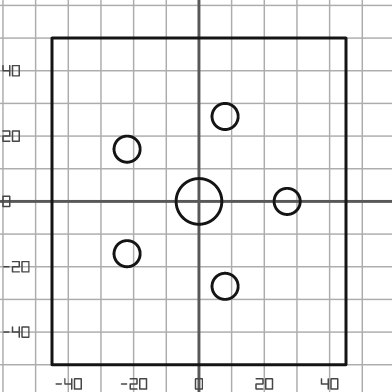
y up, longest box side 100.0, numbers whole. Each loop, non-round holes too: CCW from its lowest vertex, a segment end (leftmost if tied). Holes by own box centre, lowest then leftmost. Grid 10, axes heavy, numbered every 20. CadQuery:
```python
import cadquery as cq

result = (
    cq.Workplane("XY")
    .moveTo(-45.0, -50.0)
    .lineTo(45.0, -50.0)
    .lineTo(45.0, 50.0)
    .lineTo(-45.0, 50.0)
    .close()
    .moveTo(8.0, -26.0)
    .circle(4.0)
    .moveTo(-22.0, -16.0)
    .circle(4.0)
    .moveTo(0.0, 0.0)
    .circle(7.0)
    .moveTo(27.0, 0.0)
    .circle(4.0)
    .moveTo(-22.0, 16.0)
    .circle(4.0)
    .moveTo(8.0, 26.0)
    .circle(4.0)
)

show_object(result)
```